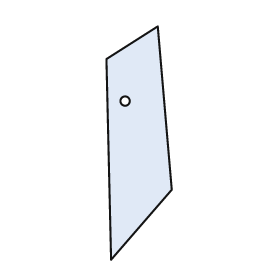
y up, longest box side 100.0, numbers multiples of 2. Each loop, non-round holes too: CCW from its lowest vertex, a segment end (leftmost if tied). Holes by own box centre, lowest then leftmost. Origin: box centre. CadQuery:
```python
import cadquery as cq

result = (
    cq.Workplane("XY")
    .moveTo(-12.0, -50.0)
    .lineTo(14.0, -20.0)
    .lineTo(8.0, 50.0)
    .lineTo(-14.0, 36.0)
    .close()
    .moveTo(-6.0, 18.0)
    .circle(2.0)
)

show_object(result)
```